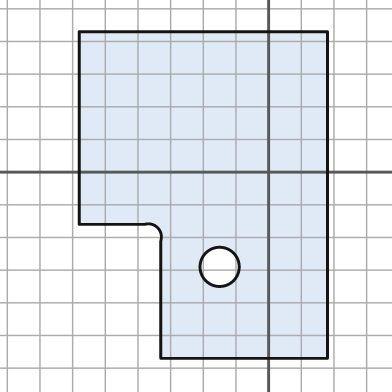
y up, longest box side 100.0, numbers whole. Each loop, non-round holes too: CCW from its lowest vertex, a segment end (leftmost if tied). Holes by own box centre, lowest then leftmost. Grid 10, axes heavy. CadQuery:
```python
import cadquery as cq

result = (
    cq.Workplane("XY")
    .moveTo(-33.0, -57.0)
    .lineTo(18.0, -57.0)
    .lineTo(18.0, 43.0)
    .lineTo(-58.0, 43.0)
    .lineTo(-58.0, -16.0)
    .lineTo(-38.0, -16.0)
    .threePointArc((-34.0, -17.0), (-33.0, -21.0))
    .close()
    .moveTo(-15.0, -29.0)
    .circle(6.0)
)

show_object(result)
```